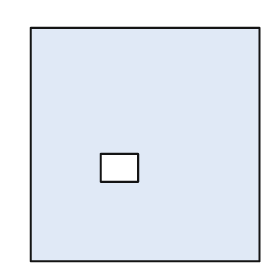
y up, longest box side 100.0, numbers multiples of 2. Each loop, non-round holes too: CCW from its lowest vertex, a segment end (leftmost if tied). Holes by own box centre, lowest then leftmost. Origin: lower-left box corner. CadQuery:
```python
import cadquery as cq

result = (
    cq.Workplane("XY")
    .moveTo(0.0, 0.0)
    .lineTo(98.0, 0.0)
    .lineTo(98.0, 100.0)
    .lineTo(0.0, 100.0)
    .close()
    .moveTo(30.0, 34.0)
    .lineTo(46.0, 34.0)
    .lineTo(46.0, 46.0)
    .lineTo(30.0, 46.0)
    .close()
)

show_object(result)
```